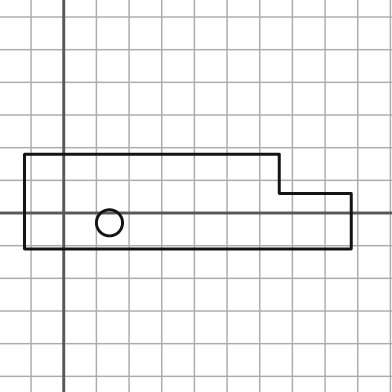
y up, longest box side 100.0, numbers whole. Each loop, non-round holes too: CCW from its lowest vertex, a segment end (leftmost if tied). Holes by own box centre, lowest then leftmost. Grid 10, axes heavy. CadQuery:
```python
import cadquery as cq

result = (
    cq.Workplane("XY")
    .moveTo(-12.0, -11.0)
    .lineTo(88.0, -11.0)
    .lineTo(88.0, 6.0)
    .lineTo(66.0, 6.0)
    .lineTo(66.0, 18.0)
    .lineTo(-12.0, 18.0)
    .close()
    .moveTo(14.0, -3.0)
    .circle(4.0)
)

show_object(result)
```